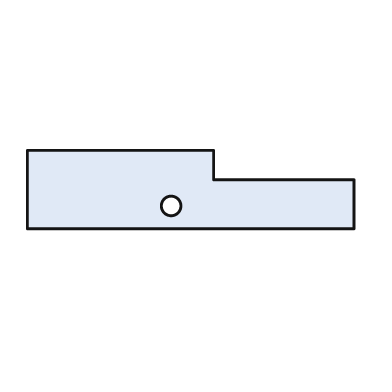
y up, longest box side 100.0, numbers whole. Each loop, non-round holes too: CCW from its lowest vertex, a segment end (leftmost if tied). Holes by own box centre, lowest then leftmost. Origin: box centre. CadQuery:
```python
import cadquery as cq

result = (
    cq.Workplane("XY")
    .moveTo(-50.0, -12.0)
    .lineTo(50.0, -12.0)
    .lineTo(50.0, 3.0)
    .lineTo(7.0, 3.0)
    .lineTo(7.0, 12.0)
    .lineTo(-50.0, 12.0)
    .close()
    .moveTo(-6.0, -5.0)
    .circle(3.0)
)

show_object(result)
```